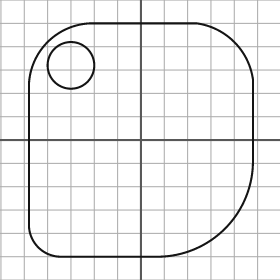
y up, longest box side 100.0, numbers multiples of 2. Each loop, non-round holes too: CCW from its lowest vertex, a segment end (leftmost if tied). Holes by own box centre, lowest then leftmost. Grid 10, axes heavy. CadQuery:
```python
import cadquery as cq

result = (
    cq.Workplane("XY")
    .moveTo(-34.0, -50.0)
    .lineTo(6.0, -50.0)
    .threePointArc((36.0, -38.0), (48.0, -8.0))
    .lineTo(48.0, 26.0)
    .threePointArc((40.0, 42.0), (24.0, 50.0))
    .lineTo(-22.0, 50.0)
    .threePointArc((-40.0, 42.0), (-48.0, 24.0))
    .lineTo(-48.0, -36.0)
    .threePointArc((-44.0, -46.0), (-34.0, -50.0))
    .close()
    .moveTo(-30.0, 32.0)
    .circle(10.0)
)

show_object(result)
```